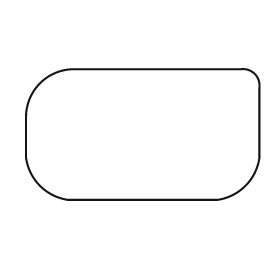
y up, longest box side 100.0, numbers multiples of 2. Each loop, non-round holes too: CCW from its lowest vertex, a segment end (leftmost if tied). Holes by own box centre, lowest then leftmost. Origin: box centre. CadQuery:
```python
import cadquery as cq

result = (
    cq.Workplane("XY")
    .moveTo(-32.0, -28.0)
    .lineTo(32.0, -28.0)
    .threePointArc((44.0, -22.0), (50.0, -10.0))
    .lineTo(50.0, 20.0)
    .threePointArc((48.0, 26.0), (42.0, 28.0))
    .lineTo(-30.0, 28.0)
    .threePointArc((-44.0, 22.0), (-50.0, 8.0))
    .lineTo(-50.0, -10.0)
    .threePointArc((-44.0, -22.0), (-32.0, -28.0))
    .close()
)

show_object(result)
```